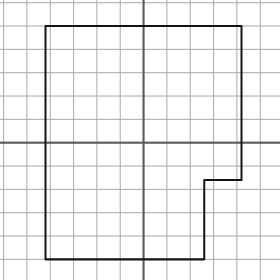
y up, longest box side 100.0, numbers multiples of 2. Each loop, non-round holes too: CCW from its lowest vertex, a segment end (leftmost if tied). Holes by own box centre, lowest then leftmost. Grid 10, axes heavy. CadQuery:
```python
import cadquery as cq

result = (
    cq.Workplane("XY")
    .moveTo(-42.0, -50.0)
    .lineTo(26.0, -50.0)
    .lineTo(26.0, -16.0)
    .lineTo(42.0, -16.0)
    .lineTo(42.0, 50.0)
    .lineTo(-42.0, 50.0)
    .close()
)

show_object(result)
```